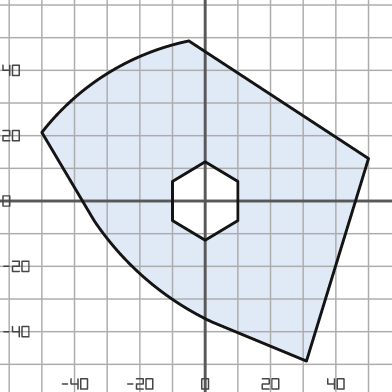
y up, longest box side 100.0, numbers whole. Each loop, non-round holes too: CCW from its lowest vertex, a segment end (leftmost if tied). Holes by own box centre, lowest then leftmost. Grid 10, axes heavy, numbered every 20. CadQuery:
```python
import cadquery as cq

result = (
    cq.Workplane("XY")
    .moveTo(31.0, -49.0)
    .lineTo(50.0, 13.0)
    .lineTo(-5.0, 49.0)
    .threePointArc((-30.0, 39.0), (-50.0, 21.0))
    .lineTo(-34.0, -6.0)
    .threePointArc((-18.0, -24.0), (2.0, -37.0))
    .close()
    .moveTo(0.0, -12.0)
    .lineTo(10.0, -6.0)
    .lineTo(10.0, 6.0)
    .lineTo(0.0, 12.0)
    .lineTo(-10.0, 6.0)
    .lineTo(-10.0, -6.0)
    .close()
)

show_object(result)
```